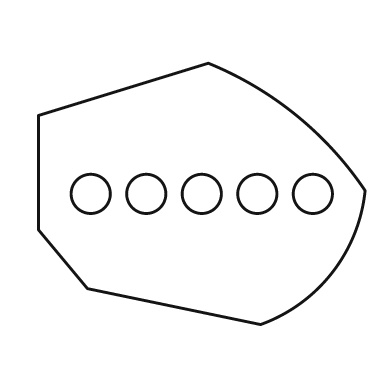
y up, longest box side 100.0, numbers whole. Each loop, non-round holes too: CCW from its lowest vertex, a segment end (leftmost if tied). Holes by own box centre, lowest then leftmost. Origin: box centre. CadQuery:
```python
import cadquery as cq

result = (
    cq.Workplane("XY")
    .moveTo(18.0, -40.0)
    .threePointArc((40.0, -24.0), (50.0, 1.0))
    .threePointArc((29.0, 24.0), (2.0, 40.0))
    .lineTo(-50.0, 24.0)
    .lineTo(-50.0, -11.0)
    .lineTo(-35.0, -29.0)
    .close()
    .moveTo(-34.0, 0.0)
    .circle(6.0)
    .moveTo(-17.0, 0.0)
    .circle(6.0)
    .moveTo(0.0, 0.0)
    .circle(6.0)
    .moveTo(17.0, 0.0)
    .circle(6.0)
    .moveTo(34.0, 0.0)
    .circle(6.0)
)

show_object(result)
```